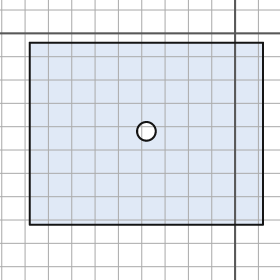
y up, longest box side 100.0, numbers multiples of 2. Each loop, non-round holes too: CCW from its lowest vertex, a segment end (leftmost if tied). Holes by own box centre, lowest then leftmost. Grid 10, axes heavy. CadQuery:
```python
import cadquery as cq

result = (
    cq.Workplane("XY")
    .moveTo(-88.0, -82.0)
    .lineTo(12.0, -82.0)
    .lineTo(12.0, -4.0)
    .lineTo(-88.0, -4.0)
    .close()
    .moveTo(-38.0, -42.0)
    .circle(4.0)
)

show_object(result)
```